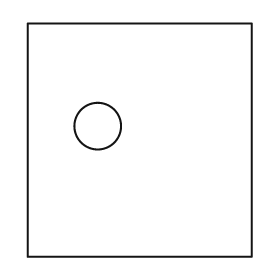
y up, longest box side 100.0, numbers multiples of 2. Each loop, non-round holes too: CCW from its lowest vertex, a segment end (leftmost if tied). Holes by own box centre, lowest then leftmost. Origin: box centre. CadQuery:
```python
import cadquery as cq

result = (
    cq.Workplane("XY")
    .moveTo(-48.0, -50.0)
    .lineTo(48.0, -50.0)
    .lineTo(48.0, 50.0)
    .lineTo(-48.0, 50.0)
    .close()
    .moveTo(-18.0, 6.0)
    .circle(10.0)
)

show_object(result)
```